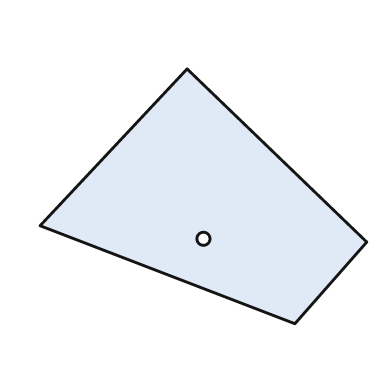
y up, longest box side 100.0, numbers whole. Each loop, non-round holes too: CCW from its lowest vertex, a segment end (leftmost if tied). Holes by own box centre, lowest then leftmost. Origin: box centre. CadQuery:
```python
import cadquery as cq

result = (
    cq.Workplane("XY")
    .moveTo(28.0, -39.0)
    .lineTo(50.0, -14.0)
    .lineTo(-5.0, 39.0)
    .lineTo(-50.0, -9.0)
    .close()
    .moveTo(0.0, -13.0)
    .circle(2.0)
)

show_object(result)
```